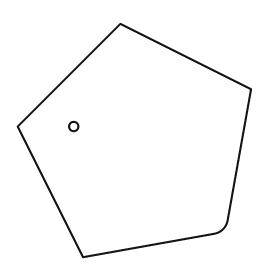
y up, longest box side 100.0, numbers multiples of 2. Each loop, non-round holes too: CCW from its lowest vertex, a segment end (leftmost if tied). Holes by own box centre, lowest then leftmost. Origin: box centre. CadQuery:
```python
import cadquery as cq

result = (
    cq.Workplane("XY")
    .moveTo(-22.0, -50.0)
    .lineTo(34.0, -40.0)
    .threePointArc((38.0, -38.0), (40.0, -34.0))
    .lineTo(50.0, 22.0)
    .lineTo(-6.0, 50.0)
    .lineTo(-50.0, 6.0)
    .close()
    .moveTo(-26.0, 6.0)
    .circle(2.0)
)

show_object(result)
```